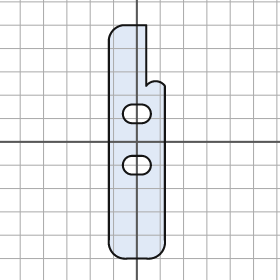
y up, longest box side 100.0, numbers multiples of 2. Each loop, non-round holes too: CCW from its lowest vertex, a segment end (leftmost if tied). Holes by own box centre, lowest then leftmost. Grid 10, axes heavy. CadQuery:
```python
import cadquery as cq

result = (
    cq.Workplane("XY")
    .moveTo(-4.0, -50.0)
    .lineTo(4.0, -50.0)
    .threePointArc((10.0, -48.0), (12.0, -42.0))
    .lineTo(12.0, 24.0)
    .threePointArc((8.0, 26.0), (4.0, 24.0))
    .lineTo(4.0, 50.0)
    .lineTo(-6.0, 50.0)
    .threePointArc((-10.0, 48.0), (-12.0, 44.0))
    .lineTo(-12.0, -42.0)
    .threePointArc((-10.0, -48.0), (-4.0, -50.0))
    .close()
    .moveTo(-2.0, -14.0)
    .lineTo(2.0, -14.0)
    .threePointArc((6.0, -10.0), (2.0, -6.0))
    .lineTo(-2.0, -6.0)
    .threePointArc((-6.0, -10.0), (-2.0, -14.0))
    .close()
    .moveTo(-2.0, 8.0)
    .lineTo(2.0, 8.0)
    .threePointArc((6.0, 12.0), (2.0, 16.0))
    .lineTo(-2.0, 16.0)
    .threePointArc((-6.0, 12.0), (-2.0, 8.0))
    .close()
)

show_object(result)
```